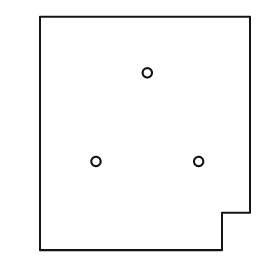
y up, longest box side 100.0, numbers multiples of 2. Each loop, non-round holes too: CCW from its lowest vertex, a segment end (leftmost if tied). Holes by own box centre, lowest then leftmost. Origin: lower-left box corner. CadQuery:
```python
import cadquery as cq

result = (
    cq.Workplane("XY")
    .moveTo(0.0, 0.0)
    .lineTo(78.0, 0.0)
    .lineTo(78.0, 16.0)
    .lineTo(90.0, 16.0)
    .lineTo(90.0, 100.0)
    .lineTo(0.0, 100.0)
    .close()
    .moveTo(24.0, 38.0)
    .circle(2.0)
    .moveTo(68.0, 38.0)
    .circle(2.0)
    .moveTo(46.0, 76.0)
    .circle(2.0)
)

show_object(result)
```